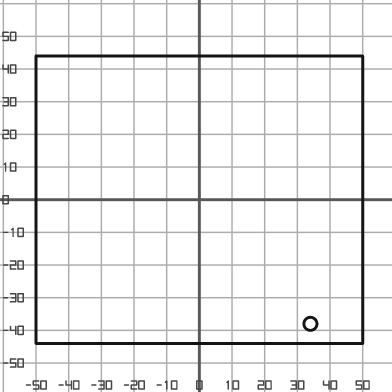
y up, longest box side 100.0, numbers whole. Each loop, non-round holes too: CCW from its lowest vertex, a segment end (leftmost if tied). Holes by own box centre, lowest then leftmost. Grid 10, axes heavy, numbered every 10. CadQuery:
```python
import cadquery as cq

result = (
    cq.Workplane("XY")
    .moveTo(-50.0, -44.0)
    .lineTo(50.0, -44.0)
    .lineTo(50.0, 44.0)
    .lineTo(-50.0, 44.0)
    .close()
    .moveTo(34.0, -38.0)
    .circle(2.0)
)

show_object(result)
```